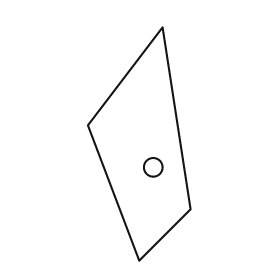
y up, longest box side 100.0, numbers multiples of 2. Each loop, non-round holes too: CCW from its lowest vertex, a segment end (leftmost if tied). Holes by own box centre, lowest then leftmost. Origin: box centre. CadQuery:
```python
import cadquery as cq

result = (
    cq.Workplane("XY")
    .moveTo(0.0, -50.0)
    .lineTo(22.0, -28.0)
    .lineTo(10.0, 50.0)
    .lineTo(-22.0, 8.0)
    .close()
    .moveTo(6.0, -10.0)
    .circle(4.0)
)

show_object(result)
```